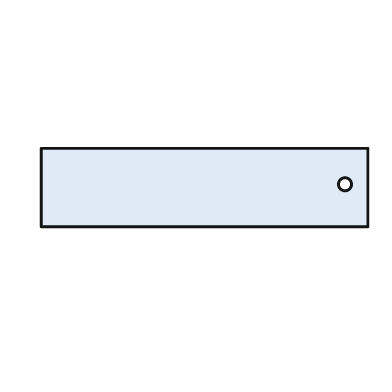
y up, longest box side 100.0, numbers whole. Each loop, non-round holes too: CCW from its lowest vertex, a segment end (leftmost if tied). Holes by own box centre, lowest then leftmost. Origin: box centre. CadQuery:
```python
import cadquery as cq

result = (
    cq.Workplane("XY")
    .moveTo(-50.0, -12.0)
    .lineTo(50.0, -12.0)
    .lineTo(50.0, 12.0)
    .lineTo(-50.0, 12.0)
    .close()
    .moveTo(43.0, 1.0)
    .circle(2.0)
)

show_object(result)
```